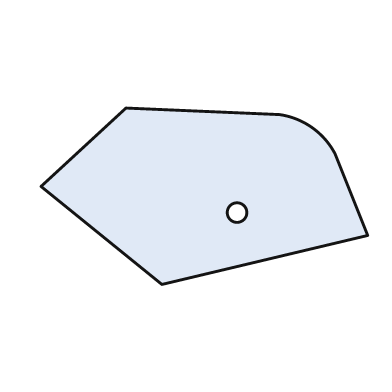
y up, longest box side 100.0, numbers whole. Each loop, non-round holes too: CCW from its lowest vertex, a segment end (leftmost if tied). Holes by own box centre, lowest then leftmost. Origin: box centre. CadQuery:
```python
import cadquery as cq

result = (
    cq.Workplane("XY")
    .moveTo(-13.0, -27.0)
    .lineTo(50.0, -12.0)
    .lineTo(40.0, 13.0)
    .threePointArc((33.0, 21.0), (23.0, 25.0))
    .lineTo(-24.0, 27.0)
    .lineTo(-50.0, 3.0)
    .close()
    .moveTo(10.0, -5.0)
    .circle(3.0)
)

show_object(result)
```